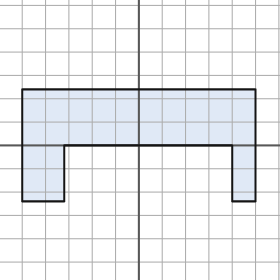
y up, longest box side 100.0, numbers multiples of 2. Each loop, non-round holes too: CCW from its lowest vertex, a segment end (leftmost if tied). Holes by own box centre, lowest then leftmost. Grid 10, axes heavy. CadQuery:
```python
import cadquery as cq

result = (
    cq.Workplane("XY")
    .moveTo(-50.0, -24.0)
    .lineTo(-32.0, -24.0)
    .lineTo(-32.0, 0.0)
    .lineTo(40.0, 0.0)
    .lineTo(40.0, -24.0)
    .lineTo(50.0, -24.0)
    .lineTo(50.0, 24.0)
    .lineTo(-50.0, 24.0)
    .close()
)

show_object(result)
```